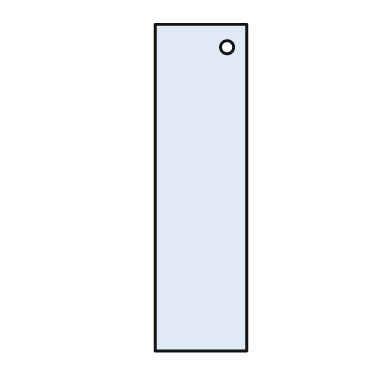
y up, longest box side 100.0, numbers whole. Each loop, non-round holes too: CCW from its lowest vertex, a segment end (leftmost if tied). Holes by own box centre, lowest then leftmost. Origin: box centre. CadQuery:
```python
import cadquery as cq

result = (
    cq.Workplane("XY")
    .moveTo(-14.0, -50.0)
    .lineTo(14.0, -50.0)
    .lineTo(14.0, 50.0)
    .lineTo(-14.0, 50.0)
    .close()
    .moveTo(8.0, 43.0)
    .circle(2.0)
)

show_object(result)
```